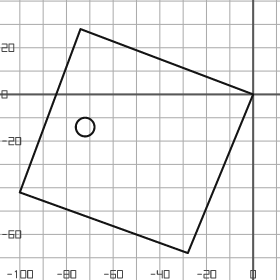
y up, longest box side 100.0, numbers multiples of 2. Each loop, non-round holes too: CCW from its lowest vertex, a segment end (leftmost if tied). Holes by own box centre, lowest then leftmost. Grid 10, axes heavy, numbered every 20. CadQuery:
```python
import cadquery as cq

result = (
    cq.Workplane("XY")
    .moveTo(-28.0, -68.0)
    .lineTo(0.0, 0.0)
    .lineTo(-74.0, 28.0)
    .lineTo(-100.0, -42.0)
    .close()
    .moveTo(-72.0, -14.0)
    .circle(4.0)
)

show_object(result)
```